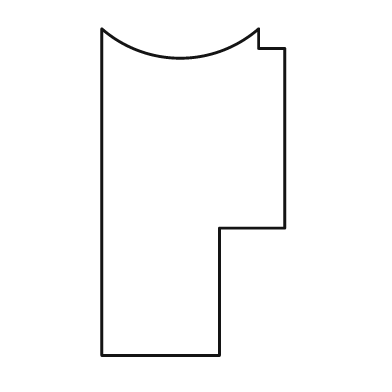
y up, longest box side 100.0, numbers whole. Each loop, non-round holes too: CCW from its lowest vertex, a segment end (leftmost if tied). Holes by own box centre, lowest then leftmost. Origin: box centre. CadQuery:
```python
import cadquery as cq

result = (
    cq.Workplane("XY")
    .moveTo(-28.0, -50.0)
    .lineTo(8.0, -50.0)
    .lineTo(8.0, -11.0)
    .lineTo(28.0, -11.0)
    .lineTo(28.0, 44.0)
    .lineTo(20.0, 44.0)
    .lineTo(20.0, 50.0)
    .threePointArc((-4.0, 41.0), (-28.0, 50.0))
    .close()
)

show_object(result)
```